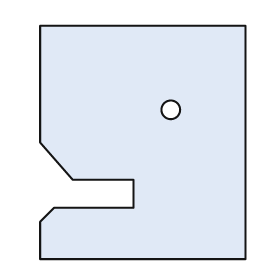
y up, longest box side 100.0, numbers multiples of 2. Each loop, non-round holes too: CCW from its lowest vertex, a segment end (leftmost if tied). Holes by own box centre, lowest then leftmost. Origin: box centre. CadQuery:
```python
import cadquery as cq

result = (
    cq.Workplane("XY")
    .moveTo(-44.0, -50.0)
    .lineTo(44.0, -50.0)
    .lineTo(44.0, 50.0)
    .lineTo(-44.0, 50.0)
    .lineTo(-44.0, 0.0)
    .lineTo(-30.0, -16.0)
    .lineTo(-4.0, -16.0)
    .lineTo(-4.0, -28.0)
    .lineTo(-38.0, -28.0)
    .lineTo(-44.0, -34.0)
    .close()
    .moveTo(12.0, 14.0)
    .circle(4.0)
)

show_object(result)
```